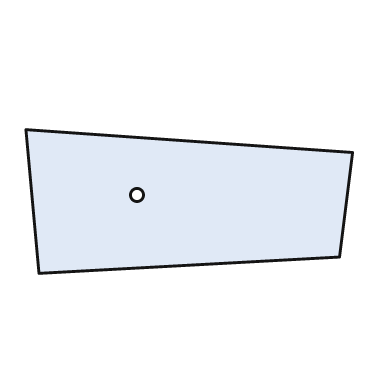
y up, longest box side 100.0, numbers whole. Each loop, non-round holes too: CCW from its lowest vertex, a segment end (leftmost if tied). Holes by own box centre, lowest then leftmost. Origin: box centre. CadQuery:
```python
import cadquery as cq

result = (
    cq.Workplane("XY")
    .moveTo(-46.0, -22.0)
    .lineTo(46.0, -17.0)
    .lineTo(50.0, 15.0)
    .lineTo(-50.0, 22.0)
    .close()
    .moveTo(-16.0, 2.0)
    .circle(2.0)
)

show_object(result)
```